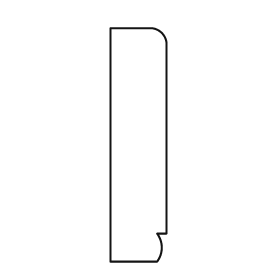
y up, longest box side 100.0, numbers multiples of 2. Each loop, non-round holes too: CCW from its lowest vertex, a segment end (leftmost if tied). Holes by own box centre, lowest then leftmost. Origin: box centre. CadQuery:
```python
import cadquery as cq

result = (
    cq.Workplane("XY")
    .moveTo(-12.0, -50.0)
    .lineTo(8.0, -50.0)
    .threePointArc((10.0, -44.0), (8.0, -38.0))
    .lineTo(12.0, -38.0)
    .lineTo(12.0, 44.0)
    .threePointArc((10.0, 48.0), (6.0, 50.0))
    .lineTo(-12.0, 50.0)
    .close()
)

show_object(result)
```